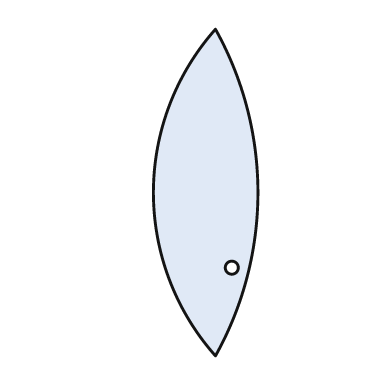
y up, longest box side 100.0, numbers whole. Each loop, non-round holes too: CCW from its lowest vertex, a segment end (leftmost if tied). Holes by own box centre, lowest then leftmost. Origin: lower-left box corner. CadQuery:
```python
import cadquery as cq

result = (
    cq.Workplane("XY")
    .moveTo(19.0, 0.0)
    .threePointArc((32.0, 50.0), (19.0, 100.0))
    .threePointArc((0.0, 50.0), (19.0, 0.0))
    .close()
    .moveTo(24.0, 27.0)
    .circle(2.0)
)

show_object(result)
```